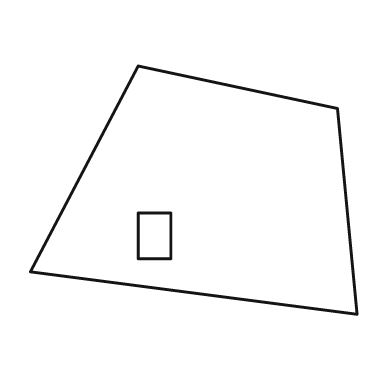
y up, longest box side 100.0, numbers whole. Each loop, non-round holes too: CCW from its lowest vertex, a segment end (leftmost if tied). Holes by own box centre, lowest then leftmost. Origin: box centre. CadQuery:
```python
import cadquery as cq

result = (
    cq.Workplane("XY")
    .moveTo(50.0, -38.0)
    .lineTo(44.0, 25.0)
    .lineTo(-17.0, 38.0)
    .lineTo(-50.0, -25.0)
    .close()
    .moveTo(-17.0, -21.0)
    .lineTo(-7.0, -21.0)
    .lineTo(-7.0, -7.0)
    .lineTo(-17.0, -7.0)
    .close()
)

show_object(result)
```